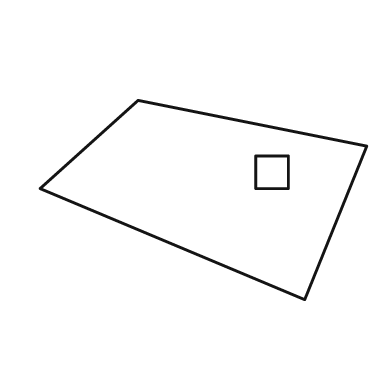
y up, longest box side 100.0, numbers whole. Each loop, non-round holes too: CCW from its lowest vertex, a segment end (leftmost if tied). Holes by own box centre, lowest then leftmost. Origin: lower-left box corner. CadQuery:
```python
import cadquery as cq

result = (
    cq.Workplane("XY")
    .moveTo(81.0, 0.0)
    .lineTo(100.0, 47.0)
    .lineTo(30.0, 61.0)
    .lineTo(0.0, 34.0)
    .close()
    .moveTo(66.0, 34.0)
    .lineTo(76.0, 34.0)
    .lineTo(76.0, 44.0)
    .lineTo(66.0, 44.0)
    .close()
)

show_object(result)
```